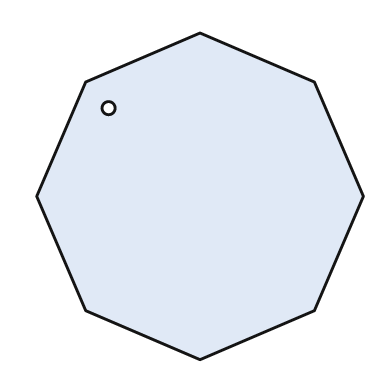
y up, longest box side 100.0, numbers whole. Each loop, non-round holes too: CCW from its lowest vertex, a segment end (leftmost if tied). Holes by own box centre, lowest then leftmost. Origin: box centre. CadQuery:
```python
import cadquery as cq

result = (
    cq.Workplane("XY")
    .moveTo(0.0, -50.0)
    .lineTo(35.0, -35.0)
    .lineTo(50.0, 0.0)
    .lineTo(35.0, 35.0)
    .lineTo(0.0, 50.0)
    .lineTo(-35.0, 35.0)
    .lineTo(-50.0, 0.0)
    .lineTo(-35.0, -35.0)
    .close()
    .moveTo(-28.0, 27.0)
    .circle(2.0)
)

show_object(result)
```